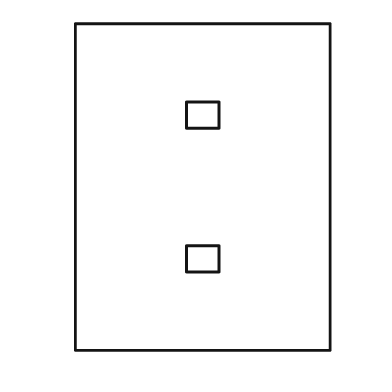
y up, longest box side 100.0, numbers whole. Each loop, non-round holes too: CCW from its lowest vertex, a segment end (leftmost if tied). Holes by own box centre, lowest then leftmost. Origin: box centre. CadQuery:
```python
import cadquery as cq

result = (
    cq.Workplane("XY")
    .moveTo(-39.0, -50.0)
    .lineTo(39.0, -50.0)
    .lineTo(39.0, 50.0)
    .lineTo(-39.0, 50.0)
    .close()
    .moveTo(-5.0, -26.0)
    .lineTo(5.0, -26.0)
    .lineTo(5.0, -18.0)
    .lineTo(-5.0, -18.0)
    .close()
    .moveTo(-5.0, 18.0)
    .lineTo(5.0, 18.0)
    .lineTo(5.0, 26.0)
    .lineTo(-5.0, 26.0)
    .close()
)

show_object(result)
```